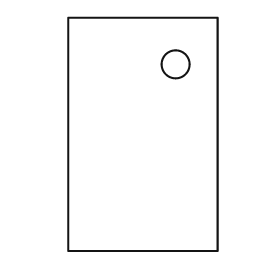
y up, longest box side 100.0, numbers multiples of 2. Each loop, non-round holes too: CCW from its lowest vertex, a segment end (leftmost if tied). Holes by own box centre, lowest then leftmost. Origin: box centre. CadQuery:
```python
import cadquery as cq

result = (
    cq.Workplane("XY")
    .moveTo(-32.0, -50.0)
    .lineTo(32.0, -50.0)
    .lineTo(32.0, 50.0)
    .lineTo(-32.0, 50.0)
    .close()
    .moveTo(14.0, 30.0)
    .circle(6.0)
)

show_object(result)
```